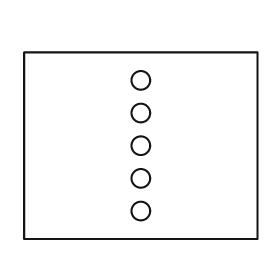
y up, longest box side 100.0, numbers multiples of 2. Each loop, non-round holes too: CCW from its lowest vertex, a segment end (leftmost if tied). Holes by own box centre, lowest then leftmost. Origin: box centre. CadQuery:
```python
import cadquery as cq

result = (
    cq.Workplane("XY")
    .moveTo(-50.0, -40.0)
    .lineTo(50.0, -40.0)
    .lineTo(50.0, 40.0)
    .lineTo(-50.0, 40.0)
    .close()
    .moveTo(0.0, -28.0)
    .circle(4.0)
    .moveTo(0.0, -14.0)
    .circle(4.0)
    .moveTo(0.0, 0.0)
    .circle(4.0)
    .moveTo(0.0, 14.0)
    .circle(4.0)
    .moveTo(0.0, 28.0)
    .circle(4.0)
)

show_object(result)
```